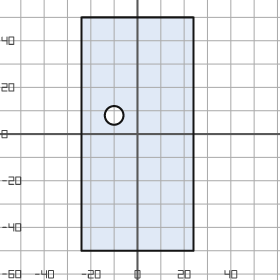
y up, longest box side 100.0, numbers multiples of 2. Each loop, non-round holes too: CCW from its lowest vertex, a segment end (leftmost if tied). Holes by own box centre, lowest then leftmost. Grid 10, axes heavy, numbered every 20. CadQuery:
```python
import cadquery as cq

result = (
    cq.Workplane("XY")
    .moveTo(-24.0, -50.0)
    .lineTo(24.0, -50.0)
    .lineTo(24.0, 50.0)
    .lineTo(-24.0, 50.0)
    .close()
    .moveTo(-10.0, 8.0)
    .circle(4.0)
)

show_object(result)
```